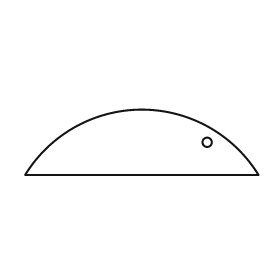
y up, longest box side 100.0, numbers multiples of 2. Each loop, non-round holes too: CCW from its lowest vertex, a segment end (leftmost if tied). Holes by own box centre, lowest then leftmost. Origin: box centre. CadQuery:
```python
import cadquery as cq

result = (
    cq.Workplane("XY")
    .moveTo(-50.0, -14.0)
    .lineTo(50.0, -14.0)
    .threePointArc((0.0, 14.0), (-50.0, -14.0))
    .close()
    .moveTo(28.0, 0.0)
    .circle(2.0)
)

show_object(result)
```